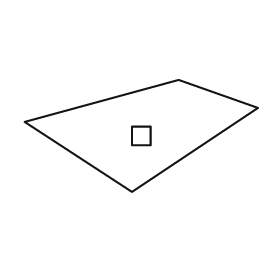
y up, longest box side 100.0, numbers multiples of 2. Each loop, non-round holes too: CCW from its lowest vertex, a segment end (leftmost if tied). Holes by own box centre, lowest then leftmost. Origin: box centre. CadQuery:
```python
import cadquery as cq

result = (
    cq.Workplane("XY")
    .moveTo(-4.0, -24.0)
    .lineTo(50.0, 12.0)
    .lineTo(16.0, 24.0)
    .lineTo(-50.0, 6.0)
    .close()
    .moveTo(-4.0, -4.0)
    .lineTo(4.0, -4.0)
    .lineTo(4.0, 4.0)
    .lineTo(-4.0, 4.0)
    .close()
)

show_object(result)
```